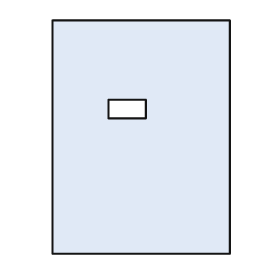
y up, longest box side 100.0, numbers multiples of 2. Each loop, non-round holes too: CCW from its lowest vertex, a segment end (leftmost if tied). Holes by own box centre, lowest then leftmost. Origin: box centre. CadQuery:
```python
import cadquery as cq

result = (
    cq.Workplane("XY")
    .moveTo(-38.0, -50.0)
    .lineTo(38.0, -50.0)
    .lineTo(38.0, 50.0)
    .lineTo(-38.0, 50.0)
    .close()
    .moveTo(-14.0, 8.0)
    .lineTo(2.0, 8.0)
    .lineTo(2.0, 16.0)
    .lineTo(-14.0, 16.0)
    .close()
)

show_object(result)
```